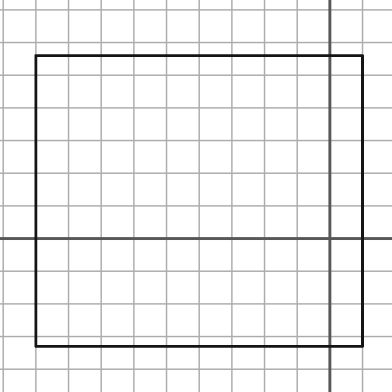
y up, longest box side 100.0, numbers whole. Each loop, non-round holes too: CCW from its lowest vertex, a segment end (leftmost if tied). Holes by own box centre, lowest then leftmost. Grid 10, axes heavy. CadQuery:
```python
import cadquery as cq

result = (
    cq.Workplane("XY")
    .moveTo(-90.0, -33.0)
    .lineTo(10.0, -33.0)
    .lineTo(10.0, 56.0)
    .lineTo(-90.0, 56.0)
    .close()
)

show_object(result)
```